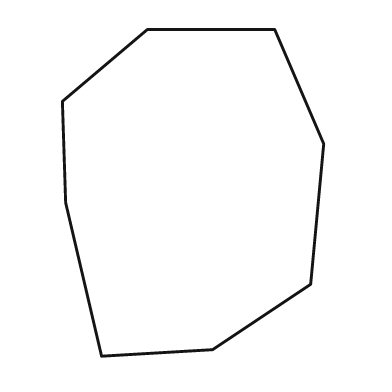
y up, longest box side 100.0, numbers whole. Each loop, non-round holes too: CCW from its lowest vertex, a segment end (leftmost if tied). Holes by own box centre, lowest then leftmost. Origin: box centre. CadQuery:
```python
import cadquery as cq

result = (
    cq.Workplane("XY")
    .moveTo(-28.0, -50.0)
    .lineTo(6.0, -48.0)
    .lineTo(36.0, -28.0)
    .lineTo(40.0, 15.0)
    .lineTo(25.0, 50.0)
    .lineTo(-14.0, 50.0)
    .lineTo(-40.0, 28.0)
    .lineTo(-39.0, -3.0)
    .close()
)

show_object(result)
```